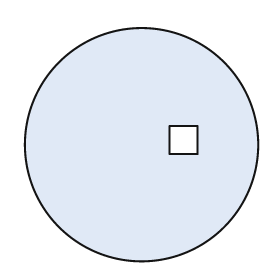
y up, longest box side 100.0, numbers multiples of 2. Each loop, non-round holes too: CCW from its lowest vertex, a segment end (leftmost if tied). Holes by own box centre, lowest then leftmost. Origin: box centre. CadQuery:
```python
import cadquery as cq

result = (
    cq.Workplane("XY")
    .moveTo(0.0, 0.0)
    .circle(50.0)
    .moveTo(12.0, -4.0)
    .lineTo(24.0, -4.0)
    .lineTo(24.0, 8.0)
    .lineTo(12.0, 8.0)
    .close()
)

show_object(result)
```